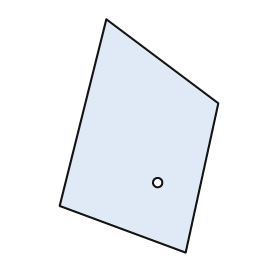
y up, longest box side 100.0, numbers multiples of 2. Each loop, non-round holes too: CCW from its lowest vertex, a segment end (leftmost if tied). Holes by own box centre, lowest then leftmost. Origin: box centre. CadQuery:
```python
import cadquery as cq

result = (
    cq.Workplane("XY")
    .moveTo(20.0, -50.0)
    .lineTo(34.0, 14.0)
    .lineTo(-14.0, 50.0)
    .lineTo(-34.0, -30.0)
    .close()
    .moveTo(8.0, -20.0)
    .circle(2.0)
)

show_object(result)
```